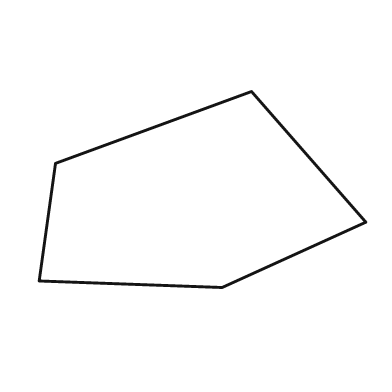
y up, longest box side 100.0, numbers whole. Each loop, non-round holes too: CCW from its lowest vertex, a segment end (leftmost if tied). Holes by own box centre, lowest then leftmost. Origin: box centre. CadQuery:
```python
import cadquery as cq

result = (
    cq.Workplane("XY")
    .moveTo(6.0, -30.0)
    .lineTo(50.0, -10.0)
    .lineTo(15.0, 30.0)
    .lineTo(-45.0, 8.0)
    .lineTo(-50.0, -28.0)
    .close()
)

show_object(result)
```